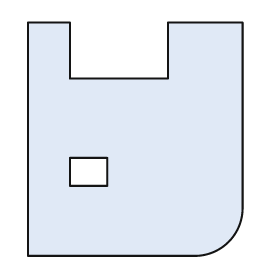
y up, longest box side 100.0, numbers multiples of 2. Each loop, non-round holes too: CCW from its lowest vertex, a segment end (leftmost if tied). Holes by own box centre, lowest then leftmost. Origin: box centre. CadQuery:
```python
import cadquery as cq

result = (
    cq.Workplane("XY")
    .moveTo(-46.0, -50.0)
    .lineTo(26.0, -50.0)
    .threePointArc((40.0, -44.0), (46.0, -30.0))
    .lineTo(46.0, 50.0)
    .lineTo(14.0, 50.0)
    .lineTo(14.0, 26.0)
    .lineTo(-28.0, 26.0)
    .lineTo(-28.0, 50.0)
    .lineTo(-46.0, 50.0)
    .close()
    .moveTo(-28.0, -20.0)
    .lineTo(-12.0, -20.0)
    .lineTo(-12.0, -8.0)
    .lineTo(-28.0, -8.0)
    .close()
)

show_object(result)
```